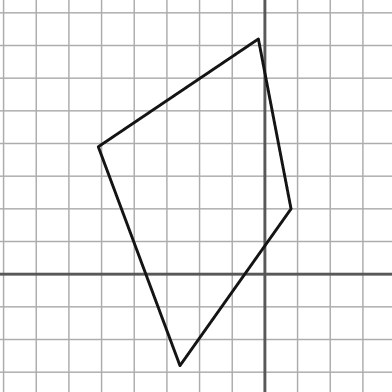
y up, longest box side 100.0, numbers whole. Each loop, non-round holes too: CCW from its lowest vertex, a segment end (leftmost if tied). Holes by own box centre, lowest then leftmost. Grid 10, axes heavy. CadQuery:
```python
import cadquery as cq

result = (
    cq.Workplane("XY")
    .moveTo(-26.0, -28.0)
    .lineTo(8.0, 20.0)
    .lineTo(-2.0, 72.0)
    .lineTo(-51.0, 39.0)
    .close()
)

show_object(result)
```